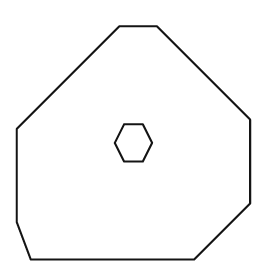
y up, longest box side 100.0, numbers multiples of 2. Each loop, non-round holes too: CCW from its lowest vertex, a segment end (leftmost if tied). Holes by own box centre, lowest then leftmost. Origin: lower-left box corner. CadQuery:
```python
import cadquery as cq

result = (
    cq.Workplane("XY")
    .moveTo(6.0, 0.0)
    .lineTo(76.0, 0.0)
    .lineTo(100.0, 24.0)
    .lineTo(100.0, 60.0)
    .lineTo(60.0, 100.0)
    .lineTo(44.0, 100.0)
    .lineTo(0.0, 56.0)
    .lineTo(0.0, 16.0)
    .close()
    .moveTo(46.0, 42.0)
    .lineTo(54.0, 42.0)
    .lineTo(58.0, 50.0)
    .lineTo(54.0, 58.0)
    .lineTo(46.0, 58.0)
    .lineTo(42.0, 50.0)
    .close()
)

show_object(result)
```